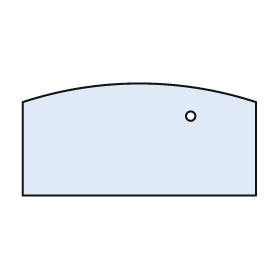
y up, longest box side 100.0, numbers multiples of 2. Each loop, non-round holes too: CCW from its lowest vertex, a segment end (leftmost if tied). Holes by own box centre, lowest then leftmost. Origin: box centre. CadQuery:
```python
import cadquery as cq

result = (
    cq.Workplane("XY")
    .moveTo(-50.0, -24.0)
    .lineTo(50.0, -24.0)
    .lineTo(50.0, 16.0)
    .threePointArc((0.0, 24.0), (-50.0, 16.0))
    .close()
    .moveTo(22.0, 10.0)
    .circle(2.0)
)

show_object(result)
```